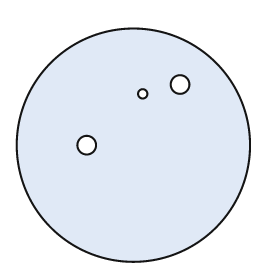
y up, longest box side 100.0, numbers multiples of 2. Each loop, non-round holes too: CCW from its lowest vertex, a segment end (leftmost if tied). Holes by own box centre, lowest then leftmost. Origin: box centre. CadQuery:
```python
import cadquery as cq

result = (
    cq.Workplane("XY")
    .moveTo(0.0, 0.0)
    .circle(50.0)
    .moveTo(-20.0, 0.0)
    .circle(4.0)
    .moveTo(4.0, 22.0)
    .circle(2.0)
    .moveTo(20.0, 26.0)
    .circle(4.0)
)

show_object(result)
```